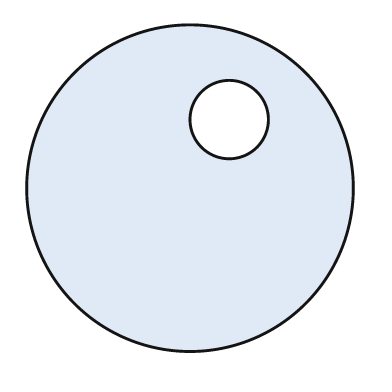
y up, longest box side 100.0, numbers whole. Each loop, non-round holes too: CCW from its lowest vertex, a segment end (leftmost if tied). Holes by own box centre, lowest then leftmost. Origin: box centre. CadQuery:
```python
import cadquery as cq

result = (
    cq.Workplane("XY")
    .moveTo(0.0, 0.0)
    .circle(50.0)
    .moveTo(12.0, 21.0)
    .circle(12.0)
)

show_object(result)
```